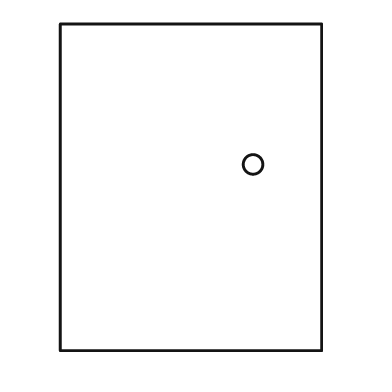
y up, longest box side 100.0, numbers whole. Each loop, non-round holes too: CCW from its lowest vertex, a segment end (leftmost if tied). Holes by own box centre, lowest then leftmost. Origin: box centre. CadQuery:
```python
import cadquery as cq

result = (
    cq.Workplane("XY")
    .moveTo(-40.0, -50.0)
    .lineTo(40.0, -50.0)
    .lineTo(40.0, 50.0)
    .lineTo(-40.0, 50.0)
    .close()
    .moveTo(19.0, 7.0)
    .circle(3.0)
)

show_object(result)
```